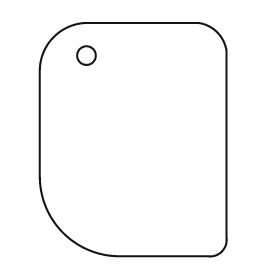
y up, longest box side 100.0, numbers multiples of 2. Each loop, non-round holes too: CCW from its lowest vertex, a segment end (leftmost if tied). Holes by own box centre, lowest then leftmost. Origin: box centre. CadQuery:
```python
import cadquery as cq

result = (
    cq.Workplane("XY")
    .moveTo(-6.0, -50.0)
    .lineTo(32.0, -50.0)
    .threePointArc((38.0, -48.0), (40.0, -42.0))
    .lineTo(40.0, 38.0)
    .threePointArc((36.0, 46.0), (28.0, 50.0))
    .lineTo(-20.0, 50.0)
    .threePointArc((-34.0, 44.0), (-40.0, 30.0))
    .lineTo(-40.0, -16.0)
    .threePointArc((-30.0, -40.0), (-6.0, -50.0))
    .close()
    .moveTo(-20.0, 36.0)
    .circle(4.0)
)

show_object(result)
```